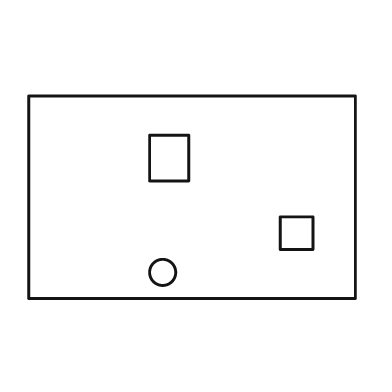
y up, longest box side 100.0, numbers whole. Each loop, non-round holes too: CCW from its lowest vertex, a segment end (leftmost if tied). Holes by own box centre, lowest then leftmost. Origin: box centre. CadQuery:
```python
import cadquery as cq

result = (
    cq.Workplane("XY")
    .moveTo(-50.0, -31.0)
    .lineTo(50.0, -31.0)
    .lineTo(50.0, 31.0)
    .lineTo(-50.0, 31.0)
    .close()
    .moveTo(-9.0, -23.0)
    .circle(4.0)
    .moveTo(27.0, -16.0)
    .lineTo(37.0, -16.0)
    .lineTo(37.0, -6.0)
    .lineTo(27.0, -6.0)
    .close()
    .moveTo(-13.0, 5.0)
    .lineTo(-1.0, 5.0)
    .lineTo(-1.0, 19.0)
    .lineTo(-13.0, 19.0)
    .close()
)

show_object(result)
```